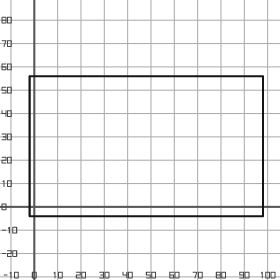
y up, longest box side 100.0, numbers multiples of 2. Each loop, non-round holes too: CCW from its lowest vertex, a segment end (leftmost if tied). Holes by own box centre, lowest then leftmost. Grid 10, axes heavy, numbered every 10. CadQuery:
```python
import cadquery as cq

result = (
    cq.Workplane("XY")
    .moveTo(-2.0, -4.0)
    .lineTo(98.0, -4.0)
    .lineTo(98.0, 56.0)
    .lineTo(-2.0, 56.0)
    .close()
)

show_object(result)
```